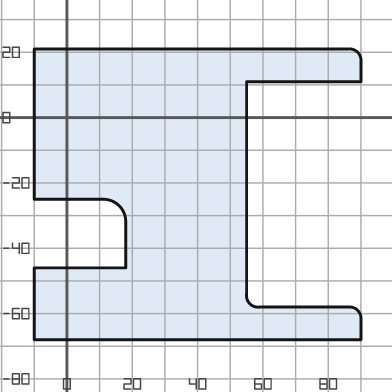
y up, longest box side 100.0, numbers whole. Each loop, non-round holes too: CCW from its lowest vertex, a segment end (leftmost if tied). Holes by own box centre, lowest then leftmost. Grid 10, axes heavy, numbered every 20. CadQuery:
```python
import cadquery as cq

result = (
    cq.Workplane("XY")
    .moveTo(-10.0, -68.0)
    .lineTo(90.0, -68.0)
    .lineTo(90.0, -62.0)
    .threePointArc((89.0, -59.0), (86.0, -58.0))
    .lineTo(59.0, -58.0)
    .threePointArc((56.0, -57.0), (55.0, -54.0))
    .lineTo(55.0, 11.0)
    .lineTo(90.0, 11.0)
    .lineTo(90.0, 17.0)
    .threePointArc((89.0, 20.0), (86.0, 21.0))
    .lineTo(-10.0, 21.0)
    .lineTo(-10.0, -25.0)
    .lineTo(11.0, -25.0)
    .threePointArc((16.0, -27.0), (18.0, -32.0))
    .lineTo(18.0, -46.0)
    .lineTo(-10.0, -46.0)
    .close()
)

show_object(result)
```